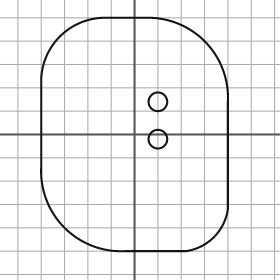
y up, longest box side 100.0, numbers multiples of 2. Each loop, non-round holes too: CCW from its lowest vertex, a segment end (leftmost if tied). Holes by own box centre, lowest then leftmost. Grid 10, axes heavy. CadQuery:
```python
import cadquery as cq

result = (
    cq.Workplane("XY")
    .moveTo(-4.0, -50.0)
    .lineTo(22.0, -50.0)
    .threePointArc((34.0, -44.0), (40.0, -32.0))
    .lineTo(40.0, 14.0)
    .threePointArc((30.0, 40.0), (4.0, 50.0))
    .lineTo(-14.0, 50.0)
    .threePointArc((-32.0, 42.0), (-40.0, 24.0))
    .lineTo(-40.0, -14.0)
    .threePointArc((-30.0, -40.0), (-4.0, -50.0))
    .close()
    .moveTo(10.0, -2.0)
    .circle(4.0)
    .moveTo(10.0, 14.0)
    .circle(4.0)
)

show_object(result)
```